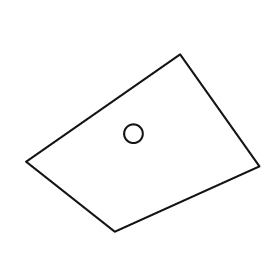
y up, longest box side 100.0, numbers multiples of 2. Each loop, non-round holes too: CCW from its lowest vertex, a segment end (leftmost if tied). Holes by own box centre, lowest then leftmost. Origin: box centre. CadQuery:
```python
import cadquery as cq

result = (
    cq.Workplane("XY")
    .moveTo(-12.0, -38.0)
    .lineTo(50.0, -10.0)
    .lineTo(16.0, 38.0)
    .lineTo(-50.0, -8.0)
    .close()
    .moveTo(-4.0, 4.0)
    .circle(4.0)
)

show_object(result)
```